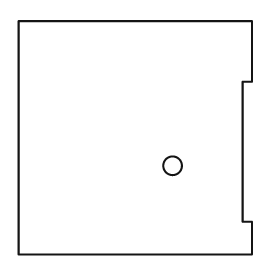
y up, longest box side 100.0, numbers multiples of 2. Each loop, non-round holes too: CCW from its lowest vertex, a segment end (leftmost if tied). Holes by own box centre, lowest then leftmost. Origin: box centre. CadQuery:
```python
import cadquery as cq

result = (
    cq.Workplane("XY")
    .moveTo(-50.0, -50.0)
    .lineTo(50.0, -50.0)
    .lineTo(50.0, -36.0)
    .lineTo(46.0, -36.0)
    .lineTo(46.0, 24.0)
    .lineTo(50.0, 24.0)
    .lineTo(50.0, 50.0)
    .lineTo(-50.0, 50.0)
    .close()
    .moveTo(16.0, -12.0)
    .circle(4.0)
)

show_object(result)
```